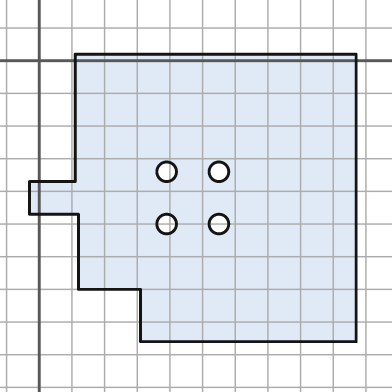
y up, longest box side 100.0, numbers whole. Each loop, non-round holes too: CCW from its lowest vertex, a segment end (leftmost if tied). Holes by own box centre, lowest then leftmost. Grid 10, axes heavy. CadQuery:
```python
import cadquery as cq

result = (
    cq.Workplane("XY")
    .moveTo(31.0, -86.0)
    .lineTo(97.0, -86.0)
    .lineTo(97.0, 2.0)
    .lineTo(11.0, 2.0)
    .lineTo(11.0, -37.0)
    .lineTo(-3.0, -37.0)
    .lineTo(-3.0, -47.0)
    .lineTo(12.0, -47.0)
    .lineTo(12.0, -70.0)
    .lineTo(31.0, -70.0)
    .close()
    .moveTo(39.0, -50.0)
    .circle(3.0)
    .moveTo(55.0, -50.0)
    .circle(3.0)
    .moveTo(39.0, -34.0)
    .circle(3.0)
    .moveTo(55.0, -34.0)
    .circle(3.0)
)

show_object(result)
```